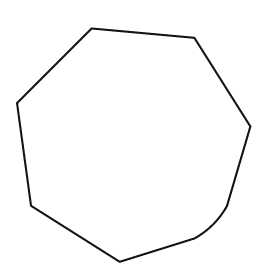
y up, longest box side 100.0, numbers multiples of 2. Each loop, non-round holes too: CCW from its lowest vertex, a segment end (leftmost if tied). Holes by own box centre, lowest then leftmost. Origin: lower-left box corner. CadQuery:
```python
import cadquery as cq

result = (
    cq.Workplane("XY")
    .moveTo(44.0, 0.0)
    .lineTo(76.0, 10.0)
    .threePointArc((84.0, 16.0), (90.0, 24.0))
    .lineTo(100.0, 58.0)
    .lineTo(76.0, 96.0)
    .lineTo(32.0, 100.0)
    .lineTo(0.0, 68.0)
    .lineTo(6.0, 24.0)
    .close()
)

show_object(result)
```